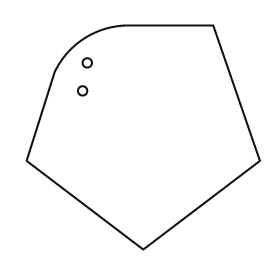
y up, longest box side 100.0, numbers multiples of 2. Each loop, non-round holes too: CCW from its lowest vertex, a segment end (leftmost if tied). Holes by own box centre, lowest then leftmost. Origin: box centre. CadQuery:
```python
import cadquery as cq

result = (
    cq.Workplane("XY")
    .moveTo(0.0, -48.0)
    .lineTo(50.0, -10.0)
    .lineTo(30.0, 48.0)
    .lineTo(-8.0, 48.0)
    .threePointArc((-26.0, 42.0), (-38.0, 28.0))
    .lineTo(-50.0, -10.0)
    .close()
    .moveTo(-26.0, 20.0)
    .circle(2.0)
    .moveTo(-24.0, 32.0)
    .circle(2.0)
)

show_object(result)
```